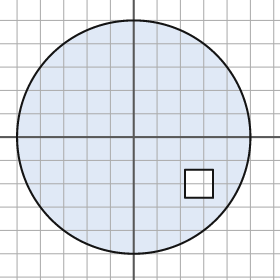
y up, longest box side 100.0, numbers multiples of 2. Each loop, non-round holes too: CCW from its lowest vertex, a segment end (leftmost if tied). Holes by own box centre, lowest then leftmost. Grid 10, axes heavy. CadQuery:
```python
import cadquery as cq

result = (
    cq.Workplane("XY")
    .moveTo(0.0, 0.0)
    .circle(50.0)
    .moveTo(22.0, -26.0)
    .lineTo(34.0, -26.0)
    .lineTo(34.0, -14.0)
    .lineTo(22.0, -14.0)
    .close()
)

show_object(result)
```